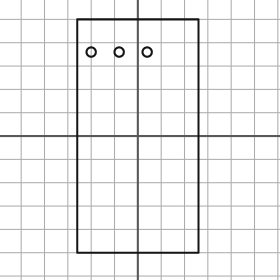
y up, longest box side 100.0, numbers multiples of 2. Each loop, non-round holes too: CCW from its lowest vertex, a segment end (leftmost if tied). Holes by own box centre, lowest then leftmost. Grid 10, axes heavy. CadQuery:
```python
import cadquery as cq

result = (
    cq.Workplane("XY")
    .moveTo(-26.0, -50.0)
    .lineTo(26.0, -50.0)
    .lineTo(26.0, 50.0)
    .lineTo(-26.0, 50.0)
    .close()
    .moveTo(-20.0, 36.0)
    .circle(2.0)
    .moveTo(-8.0, 36.0)
    .circle(2.0)
    .moveTo(4.0, 36.0)
    .circle(2.0)
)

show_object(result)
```